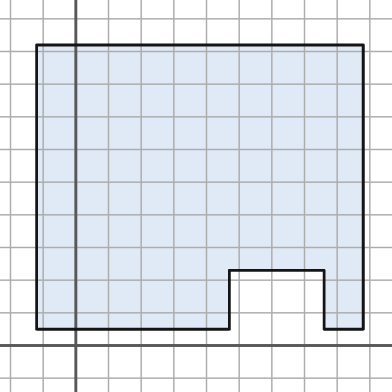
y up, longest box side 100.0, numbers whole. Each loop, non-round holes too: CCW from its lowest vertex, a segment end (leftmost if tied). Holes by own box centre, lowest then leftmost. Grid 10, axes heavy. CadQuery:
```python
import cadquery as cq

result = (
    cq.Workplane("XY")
    .moveTo(-12.0, 5.0)
    .lineTo(47.0, 5.0)
    .lineTo(47.0, 23.0)
    .lineTo(76.0, 23.0)
    .lineTo(76.0, 5.0)
    .lineTo(88.0, 5.0)
    .lineTo(88.0, 92.0)
    .lineTo(-12.0, 92.0)
    .close()
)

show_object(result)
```